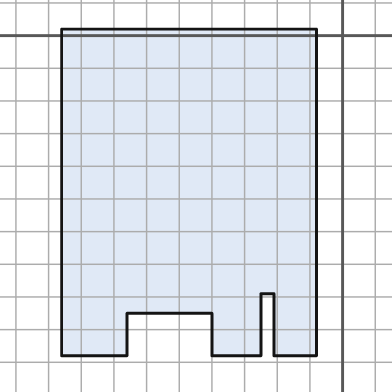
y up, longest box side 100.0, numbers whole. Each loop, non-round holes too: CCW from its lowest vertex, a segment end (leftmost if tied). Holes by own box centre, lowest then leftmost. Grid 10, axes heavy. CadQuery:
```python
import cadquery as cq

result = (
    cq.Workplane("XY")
    .moveTo(-86.0, -98.0)
    .lineTo(-66.0, -98.0)
    .lineTo(-66.0, -85.0)
    .lineTo(-40.0, -85.0)
    .lineTo(-40.0, -98.0)
    .lineTo(-25.0, -98.0)
    .lineTo(-25.0, -79.0)
    .lineTo(-21.0, -79.0)
    .lineTo(-21.0, -98.0)
    .lineTo(-8.0, -98.0)
    .lineTo(-8.0, 2.0)
    .lineTo(-86.0, 2.0)
    .close()
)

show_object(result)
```